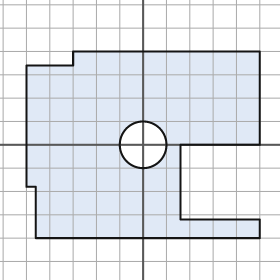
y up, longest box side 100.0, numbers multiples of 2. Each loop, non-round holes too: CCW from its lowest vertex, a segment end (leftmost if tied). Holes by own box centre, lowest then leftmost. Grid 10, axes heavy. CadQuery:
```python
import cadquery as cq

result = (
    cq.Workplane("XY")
    .moveTo(-46.0, -40.0)
    .lineTo(50.0, -40.0)
    .lineTo(50.0, -32.0)
    .lineTo(16.0, -32.0)
    .lineTo(16.0, 0.0)
    .lineTo(50.0, 0.0)
    .lineTo(50.0, 40.0)
    .lineTo(-30.0, 40.0)
    .lineTo(-30.0, 34.0)
    .lineTo(-50.0, 34.0)
    .lineTo(-50.0, -18.0)
    .lineTo(-46.0, -18.0)
    .close()
    .moveTo(0.0, 0.0)
    .circle(10.0)
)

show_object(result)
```